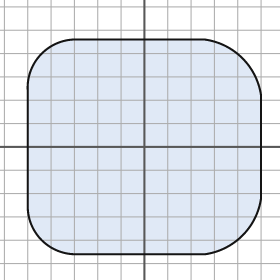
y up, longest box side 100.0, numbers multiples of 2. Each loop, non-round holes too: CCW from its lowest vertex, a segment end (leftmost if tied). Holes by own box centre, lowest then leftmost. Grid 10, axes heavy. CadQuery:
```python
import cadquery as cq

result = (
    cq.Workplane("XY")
    .moveTo(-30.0, -46.0)
    .lineTo(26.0, -46.0)
    .threePointArc((42.0, -38.0), (50.0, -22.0))
    .lineTo(50.0, 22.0)
    .threePointArc((42.0, 38.0), (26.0, 46.0))
    .lineTo(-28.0, 46.0)
    .threePointArc((-44.0, 40.0), (-50.0, 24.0))
    .lineTo(-50.0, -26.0)
    .threePointArc((-44.0, -40.0), (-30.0, -46.0))
    .close()
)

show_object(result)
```